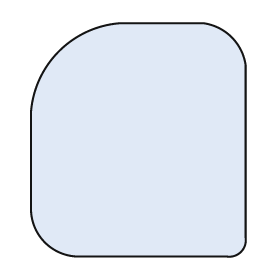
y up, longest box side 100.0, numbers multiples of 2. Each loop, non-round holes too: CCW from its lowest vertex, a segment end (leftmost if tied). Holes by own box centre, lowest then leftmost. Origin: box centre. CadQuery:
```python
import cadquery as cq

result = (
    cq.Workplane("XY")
    .moveTo(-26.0, -50.0)
    .lineTo(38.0, -50.0)
    .threePointArc((44.0, -48.0), (46.0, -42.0))
    .lineTo(46.0, 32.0)
    .threePointArc((40.0, 44.0), (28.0, 50.0))
    .lineTo(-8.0, 50.0)
    .threePointArc((-34.0, 38.0), (-46.0, 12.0))
    .lineTo(-46.0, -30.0)
    .threePointArc((-40.0, -44.0), (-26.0, -50.0))
    .close()
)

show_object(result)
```